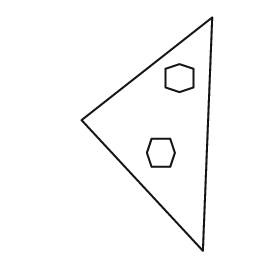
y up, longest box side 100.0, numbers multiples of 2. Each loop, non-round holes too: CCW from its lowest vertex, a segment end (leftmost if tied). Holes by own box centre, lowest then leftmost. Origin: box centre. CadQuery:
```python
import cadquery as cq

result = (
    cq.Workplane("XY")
    .moveTo(24.0, -50.0)
    .lineTo(28.0, 50.0)
    .lineTo(-28.0, 6.0)
    .close()
    .moveTo(2.0, -14.0)
    .lineTo(10.0, -14.0)
    .lineTo(12.0, -8.0)
    .lineTo(10.0, -2.0)
    .lineTo(2.0, -2.0)
    .lineTo(0.0, -8.0)
    .close()
    .moveTo(14.0, 18.0)
    .lineTo(20.0, 20.0)
    .lineTo(20.0, 28.0)
    .lineTo(14.0, 30.0)
    .lineTo(8.0, 28.0)
    .lineTo(8.0, 20.0)
    .close()
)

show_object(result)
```